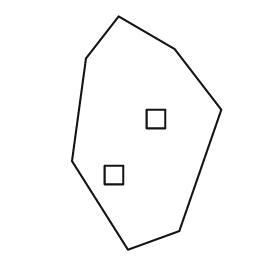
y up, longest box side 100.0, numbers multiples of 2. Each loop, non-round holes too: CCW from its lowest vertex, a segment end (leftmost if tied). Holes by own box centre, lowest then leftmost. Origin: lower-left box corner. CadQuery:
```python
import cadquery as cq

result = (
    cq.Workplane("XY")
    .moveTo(24.0, 0.0)
    .lineTo(46.0, 8.0)
    .lineTo(64.0, 60.0)
    .lineTo(44.0, 86.0)
    .lineTo(20.0, 100.0)
    .lineTo(6.0, 82.0)
    .lineTo(0.0, 38.0)
    .close()
    .moveTo(14.0, 28.0)
    .lineTo(22.0, 28.0)
    .lineTo(22.0, 36.0)
    .lineTo(14.0, 36.0)
    .close()
    .moveTo(32.0, 52.0)
    .lineTo(40.0, 52.0)
    .lineTo(40.0, 60.0)
    .lineTo(32.0, 60.0)
    .close()
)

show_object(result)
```